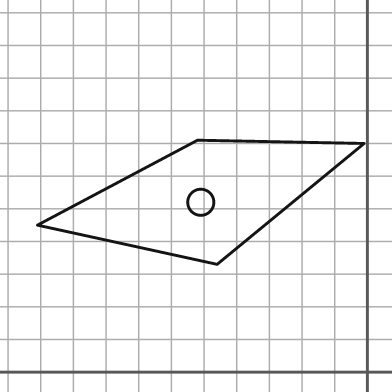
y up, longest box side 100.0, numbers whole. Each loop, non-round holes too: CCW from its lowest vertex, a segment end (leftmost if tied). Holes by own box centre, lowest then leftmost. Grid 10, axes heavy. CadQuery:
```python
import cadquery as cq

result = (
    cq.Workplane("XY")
    .moveTo(-46.0, 33.0)
    .lineTo(-1.0, 70.0)
    .lineTo(-52.0, 71.0)
    .lineTo(-101.0, 45.0)
    .close()
    .moveTo(-51.0, 52.0)
    .circle(4.0)
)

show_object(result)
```